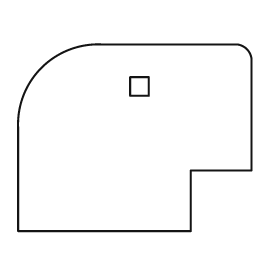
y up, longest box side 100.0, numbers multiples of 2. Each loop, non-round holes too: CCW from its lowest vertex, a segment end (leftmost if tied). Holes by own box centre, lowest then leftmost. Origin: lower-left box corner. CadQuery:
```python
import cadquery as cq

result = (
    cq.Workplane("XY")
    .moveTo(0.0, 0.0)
    .lineTo(74.0, 0.0)
    .lineTo(74.0, 26.0)
    .lineTo(100.0, 26.0)
    .lineTo(100.0, 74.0)
    .threePointArc((98.0, 78.0), (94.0, 80.0))
    .lineTo(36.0, 80.0)
    .threePointArc((10.0, 70.0), (0.0, 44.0))
    .close()
    .moveTo(48.0, 58.0)
    .lineTo(56.0, 58.0)
    .lineTo(56.0, 66.0)
    .lineTo(48.0, 66.0)
    .close()
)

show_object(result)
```